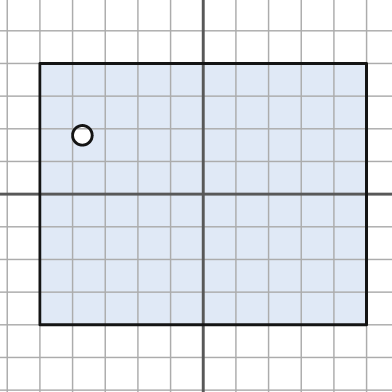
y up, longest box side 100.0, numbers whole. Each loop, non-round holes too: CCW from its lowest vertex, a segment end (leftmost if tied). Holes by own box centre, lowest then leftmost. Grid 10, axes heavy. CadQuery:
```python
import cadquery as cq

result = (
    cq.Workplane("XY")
    .moveTo(-50.0, -40.0)
    .lineTo(50.0, -40.0)
    .lineTo(50.0, 40.0)
    .lineTo(-50.0, 40.0)
    .close()
    .moveTo(-37.0, 18.0)
    .circle(3.0)
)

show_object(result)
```